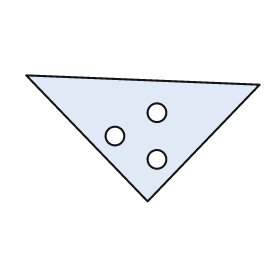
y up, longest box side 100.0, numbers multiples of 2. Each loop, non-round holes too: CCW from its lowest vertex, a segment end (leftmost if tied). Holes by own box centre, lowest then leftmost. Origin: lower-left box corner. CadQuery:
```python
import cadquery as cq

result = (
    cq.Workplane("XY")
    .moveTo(52.0, 0.0)
    .lineTo(100.0, 50.0)
    .lineTo(0.0, 54.0)
    .close()
    .moveTo(56.0, 18.0)
    .circle(4.0)
    .moveTo(38.0, 28.0)
    .circle(4.0)
    .moveTo(56.0, 38.0)
    .circle(4.0)
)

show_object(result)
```